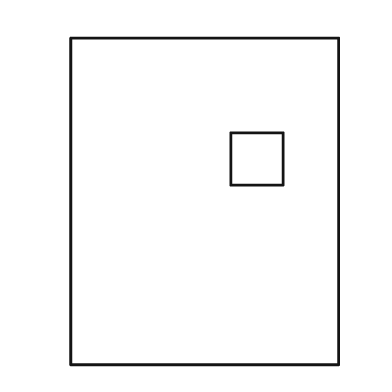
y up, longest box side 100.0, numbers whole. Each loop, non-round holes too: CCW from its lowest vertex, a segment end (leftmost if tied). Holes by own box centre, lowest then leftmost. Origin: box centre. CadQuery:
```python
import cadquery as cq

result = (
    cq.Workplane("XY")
    .moveTo(-41.0, -50.0)
    .lineTo(41.0, -50.0)
    .lineTo(41.0, 50.0)
    .lineTo(-41.0, 50.0)
    .close()
    .moveTo(8.0, 5.0)
    .lineTo(24.0, 5.0)
    .lineTo(24.0, 21.0)
    .lineTo(8.0, 21.0)
    .close()
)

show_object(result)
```